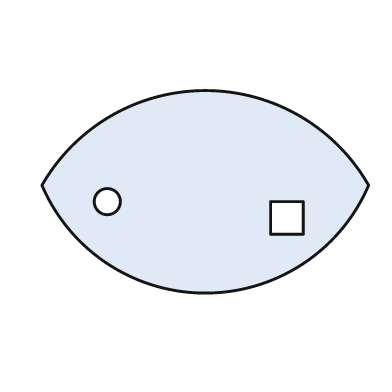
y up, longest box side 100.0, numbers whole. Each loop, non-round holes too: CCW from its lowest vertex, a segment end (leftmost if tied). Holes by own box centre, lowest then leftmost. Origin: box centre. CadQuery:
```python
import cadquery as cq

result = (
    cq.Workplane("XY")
    .moveTo(-50.0, 2.0)
    .threePointArc((0.0, -31.0), (50.0, 2.0))
    .threePointArc((0.0, 31.0), (-50.0, 2.0))
    .close()
    .moveTo(20.0, -13.0)
    .lineTo(30.0, -13.0)
    .lineTo(30.0, -3.0)
    .lineTo(20.0, -3.0)
    .close()
    .moveTo(-30.0, -3.0)
    .circle(4.0)
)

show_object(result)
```